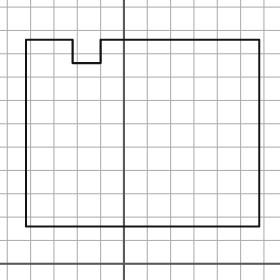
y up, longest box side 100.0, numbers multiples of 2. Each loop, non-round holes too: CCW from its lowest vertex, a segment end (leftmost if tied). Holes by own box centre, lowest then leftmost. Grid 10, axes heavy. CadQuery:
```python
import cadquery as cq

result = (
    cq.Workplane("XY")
    .moveTo(-42.0, 16.0)
    .lineTo(58.0, 16.0)
    .lineTo(58.0, 96.0)
    .lineTo(-10.0, 96.0)
    .lineTo(-10.0, 86.0)
    .lineTo(-22.0, 86.0)
    .lineTo(-22.0, 96.0)
    .lineTo(-42.0, 96.0)
    .close()
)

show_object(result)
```